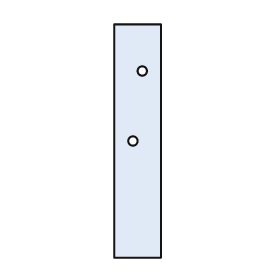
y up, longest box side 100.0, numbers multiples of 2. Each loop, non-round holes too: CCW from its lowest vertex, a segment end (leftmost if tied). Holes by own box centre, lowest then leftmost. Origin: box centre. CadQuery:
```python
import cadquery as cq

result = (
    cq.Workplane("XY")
    .moveTo(-10.0, -50.0)
    .lineTo(10.0, -50.0)
    .lineTo(10.0, 50.0)
    .lineTo(-10.0, 50.0)
    .close()
    .moveTo(-2.0, 0.0)
    .circle(2.0)
    .moveTo(2.0, 30.0)
    .circle(2.0)
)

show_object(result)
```